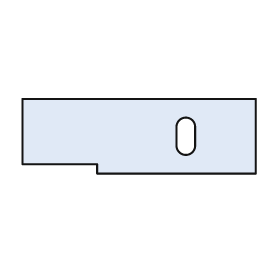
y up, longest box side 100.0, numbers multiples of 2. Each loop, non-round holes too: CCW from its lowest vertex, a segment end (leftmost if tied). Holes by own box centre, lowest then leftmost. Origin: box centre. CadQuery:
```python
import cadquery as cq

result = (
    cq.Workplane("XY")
    .moveTo(-18.0, -16.0)
    .lineTo(50.0, -16.0)
    .lineTo(50.0, 16.0)
    .lineTo(-50.0, 16.0)
    .lineTo(-50.0, -12.0)
    .lineTo(-18.0, -12.0)
    .close()
    .moveTo(16.0, -4.0)
    .threePointArc((20.0, -8.0), (24.0, -4.0))
    .lineTo(24.0, 4.0)
    .threePointArc((20.0, 8.0), (16.0, 4.0))
    .close()
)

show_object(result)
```